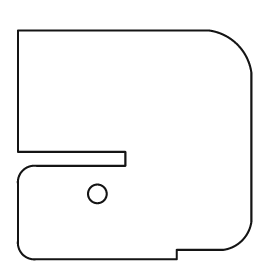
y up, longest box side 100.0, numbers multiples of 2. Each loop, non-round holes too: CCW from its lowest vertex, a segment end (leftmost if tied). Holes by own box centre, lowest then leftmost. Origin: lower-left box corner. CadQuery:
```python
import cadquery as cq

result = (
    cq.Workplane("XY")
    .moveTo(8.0, 0.0)
    .lineTo(68.0, 0.0)
    .lineTo(68.0, 4.0)
    .lineTo(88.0, 4.0)
    .threePointArc((96.0, 8.0), (100.0, 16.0))
    .lineTo(100.0, 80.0)
    .threePointArc((94.0, 92.0), (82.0, 98.0))
    .lineTo(0.0, 98.0)
    .lineTo(0.0, 46.0)
    .lineTo(46.0, 46.0)
    .lineTo(46.0, 40.0)
    .lineTo(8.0, 40.0)
    .threePointArc((2.0, 38.0), (0.0, 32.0))
    .lineTo(0.0, 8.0)
    .threePointArc((2.0, 2.0), (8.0, 0.0))
    .close()
    .moveTo(34.0, 28.0)
    .circle(4.0)
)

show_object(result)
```